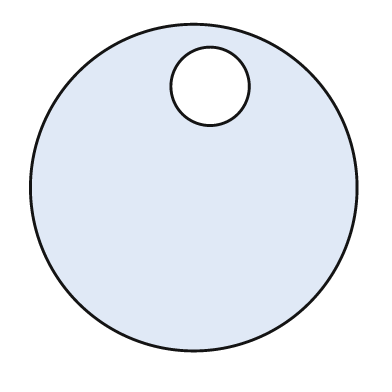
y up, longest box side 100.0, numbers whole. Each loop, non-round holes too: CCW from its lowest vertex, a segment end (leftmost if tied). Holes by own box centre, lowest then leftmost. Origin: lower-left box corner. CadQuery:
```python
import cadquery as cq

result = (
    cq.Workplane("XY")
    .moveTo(50.0, 50.0)
    .circle(50.0)
    .moveTo(55.0, 81.0)
    .circle(12.0)
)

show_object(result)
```